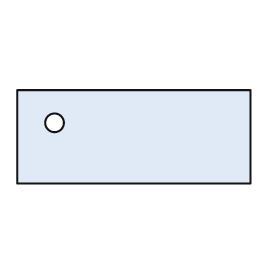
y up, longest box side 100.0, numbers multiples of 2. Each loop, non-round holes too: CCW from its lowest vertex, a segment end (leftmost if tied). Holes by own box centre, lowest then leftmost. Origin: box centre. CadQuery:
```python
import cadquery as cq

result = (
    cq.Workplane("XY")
    .moveTo(-50.0, -20.0)
    .lineTo(50.0, -20.0)
    .lineTo(50.0, 20.0)
    .lineTo(-50.0, 20.0)
    .close()
    .moveTo(-34.0, 6.0)
    .circle(4.0)
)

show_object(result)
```